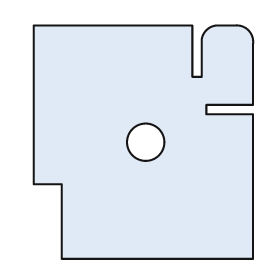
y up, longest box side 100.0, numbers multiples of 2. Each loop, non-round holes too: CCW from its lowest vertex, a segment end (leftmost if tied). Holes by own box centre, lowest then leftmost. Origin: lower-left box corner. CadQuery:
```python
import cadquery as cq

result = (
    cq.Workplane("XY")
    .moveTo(12.0, 0.0)
    .lineTo(94.0, 0.0)
    .lineTo(94.0, 62.0)
    .lineTo(74.0, 62.0)
    .lineTo(74.0, 66.0)
    .lineTo(94.0, 66.0)
    .lineTo(94.0, 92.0)
    .threePointArc((92.0, 98.0), (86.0, 100.0))
    .lineTo(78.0, 100.0)
    .threePointArc((74.0, 98.0), (72.0, 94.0))
    .lineTo(72.0, 78.0)
    .lineTo(68.0, 78.0)
    .lineTo(68.0, 100.0)
    .lineTo(0.0, 100.0)
    .lineTo(0.0, 32.0)
    .lineTo(12.0, 32.0)
    .close()
    .moveTo(48.0, 50.0)
    .circle(8.0)
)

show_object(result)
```